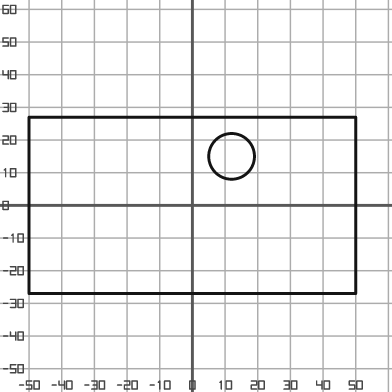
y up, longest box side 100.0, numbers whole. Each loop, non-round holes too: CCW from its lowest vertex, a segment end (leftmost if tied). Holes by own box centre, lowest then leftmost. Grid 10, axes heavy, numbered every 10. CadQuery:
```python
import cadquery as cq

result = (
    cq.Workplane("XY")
    .moveTo(-50.0, -27.0)
    .lineTo(50.0, -27.0)
    .lineTo(50.0, 27.0)
    .lineTo(-50.0, 27.0)
    .close()
    .moveTo(12.0, 15.0)
    .circle(7.0)
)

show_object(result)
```